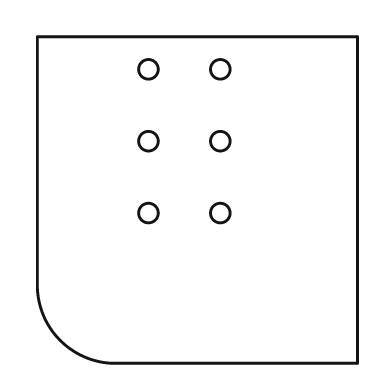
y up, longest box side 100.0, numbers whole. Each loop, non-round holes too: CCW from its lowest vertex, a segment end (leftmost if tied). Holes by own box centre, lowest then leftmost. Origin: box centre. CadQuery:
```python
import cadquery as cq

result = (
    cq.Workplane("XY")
    .moveTo(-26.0, -50.0)
    .lineTo(49.0, -50.0)
    .lineTo(49.0, 50.0)
    .lineTo(-49.0, 50.0)
    .lineTo(-49.0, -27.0)
    .threePointArc((-42.0, -43.0), (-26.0, -50.0))
    .close()
    .moveTo(-15.0, -4.0)
    .circle(3.0)
    .moveTo(7.0, -4.0)
    .circle(3.0)
    .moveTo(-15.0, 18.0)
    .circle(3.0)
    .moveTo(7.0, 18.0)
    .circle(3.0)
    .moveTo(-15.0, 40.0)
    .circle(3.0)
    .moveTo(7.0, 40.0)
    .circle(3.0)
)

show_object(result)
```